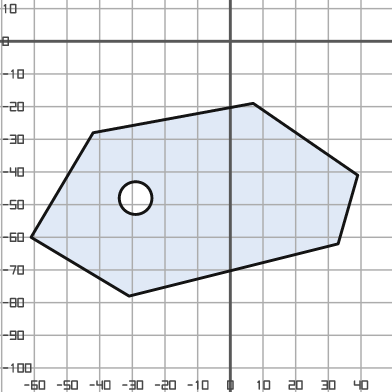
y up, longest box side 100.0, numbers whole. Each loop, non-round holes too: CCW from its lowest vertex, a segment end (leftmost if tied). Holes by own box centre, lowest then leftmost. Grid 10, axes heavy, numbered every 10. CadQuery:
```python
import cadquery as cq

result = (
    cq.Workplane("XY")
    .moveTo(-31.0, -78.0)
    .lineTo(33.0, -62.0)
    .lineTo(39.0, -41.0)
    .lineTo(7.0, -19.0)
    .lineTo(-42.0, -28.0)
    .lineTo(-61.0, -60.0)
    .close()
    .moveTo(-29.0, -48.0)
    .circle(5.0)
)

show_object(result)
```